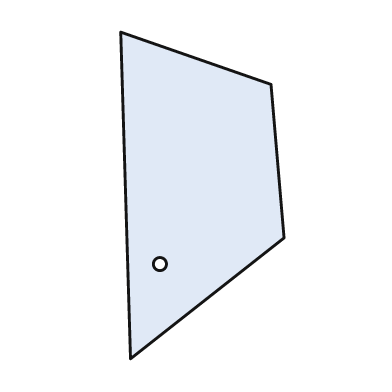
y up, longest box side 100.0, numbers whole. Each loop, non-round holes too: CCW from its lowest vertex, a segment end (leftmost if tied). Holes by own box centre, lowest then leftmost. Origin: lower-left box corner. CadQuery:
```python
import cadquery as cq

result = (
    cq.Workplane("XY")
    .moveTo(3.0, 0.0)
    .lineTo(50.0, 37.0)
    .lineTo(46.0, 84.0)
    .lineTo(0.0, 100.0)
    .close()
    .moveTo(12.0, 29.0)
    .circle(2.0)
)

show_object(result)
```